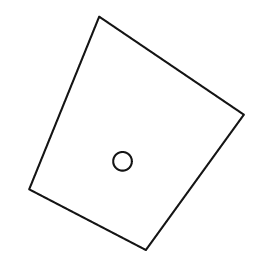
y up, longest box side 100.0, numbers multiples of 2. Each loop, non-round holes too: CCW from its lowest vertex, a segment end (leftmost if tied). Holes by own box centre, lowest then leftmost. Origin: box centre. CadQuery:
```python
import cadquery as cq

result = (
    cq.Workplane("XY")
    .moveTo(4.0, -50.0)
    .lineTo(46.0, 8.0)
    .lineTo(-16.0, 50.0)
    .lineTo(-46.0, -24.0)
    .close()
    .moveTo(-6.0, -12.0)
    .circle(4.0)
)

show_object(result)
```